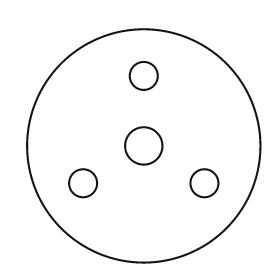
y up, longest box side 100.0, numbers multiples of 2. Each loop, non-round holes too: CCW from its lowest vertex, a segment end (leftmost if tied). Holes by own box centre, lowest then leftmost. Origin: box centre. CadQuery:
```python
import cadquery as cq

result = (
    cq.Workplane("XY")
    .moveTo(0.0, 0.0)
    .circle(50.0)
    .moveTo(-26.0, -16.0)
    .circle(6.0)
    .moveTo(26.0, -16.0)
    .circle(6.0)
    .moveTo(0.0, 0.0)
    .circle(8.0)
    .moveTo(0.0, 30.0)
    .circle(6.0)
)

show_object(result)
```